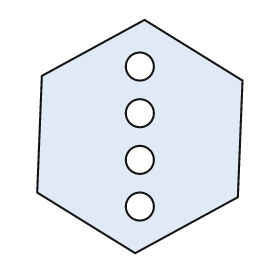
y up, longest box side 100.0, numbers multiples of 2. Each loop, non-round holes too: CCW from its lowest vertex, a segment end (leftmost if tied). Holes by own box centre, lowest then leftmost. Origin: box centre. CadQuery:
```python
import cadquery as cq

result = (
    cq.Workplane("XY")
    .moveTo(-2.0, -50.0)
    .lineTo(42.0, -26.0)
    .lineTo(44.0, 24.0)
    .lineTo(2.0, 50.0)
    .lineTo(-42.0, 26.0)
    .lineTo(-44.0, -24.0)
    .close()
    .moveTo(0.0, -30.0)
    .circle(6.0)
    .moveTo(0.0, -10.0)
    .circle(6.0)
    .moveTo(0.0, 10.0)
    .circle(6.0)
    .moveTo(0.0, 30.0)
    .circle(6.0)
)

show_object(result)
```